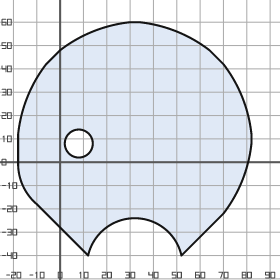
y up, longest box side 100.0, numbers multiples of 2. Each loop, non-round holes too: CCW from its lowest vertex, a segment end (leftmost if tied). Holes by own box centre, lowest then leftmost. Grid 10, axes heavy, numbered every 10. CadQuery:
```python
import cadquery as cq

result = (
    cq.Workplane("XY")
    .moveTo(12.0, -40.0)
    .threePointArc((32.0, -24.0), (52.0, -40.0))
    .lineTo(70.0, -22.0)
    .threePointArc((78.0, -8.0), (82.0, 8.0))
    .lineTo(82.0, 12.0)
    .threePointArc((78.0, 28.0), (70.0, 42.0))
    .lineTo(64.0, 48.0)
    .threePointArc((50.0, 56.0), (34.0, 60.0))
    .lineTo(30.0, 60.0)
    .threePointArc((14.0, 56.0), (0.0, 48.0))
    .lineTo(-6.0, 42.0)
    .threePointArc((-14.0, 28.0), (-18.0, 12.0))
    .lineTo(-18.0, 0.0)
    .threePointArc((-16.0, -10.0), (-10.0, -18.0))
    .close()
    .moveTo(8.0, 8.0)
    .circle(6.0)
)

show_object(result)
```